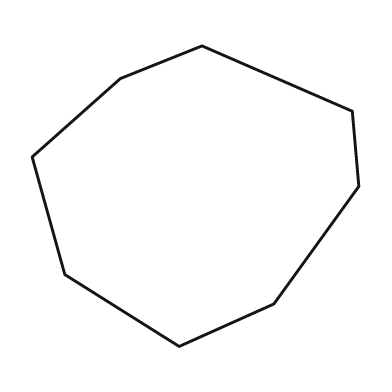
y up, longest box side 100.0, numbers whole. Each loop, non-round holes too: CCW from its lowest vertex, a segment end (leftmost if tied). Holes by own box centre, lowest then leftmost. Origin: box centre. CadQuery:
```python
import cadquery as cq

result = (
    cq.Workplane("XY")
    .moveTo(-5.0, -46.0)
    .lineTo(24.0, -33.0)
    .lineTo(50.0, 3.0)
    .lineTo(48.0, 26.0)
    .lineTo(2.0, 46.0)
    .lineTo(-23.0, 36.0)
    .lineTo(-50.0, 12.0)
    .lineTo(-40.0, -24.0)
    .close()
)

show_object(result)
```